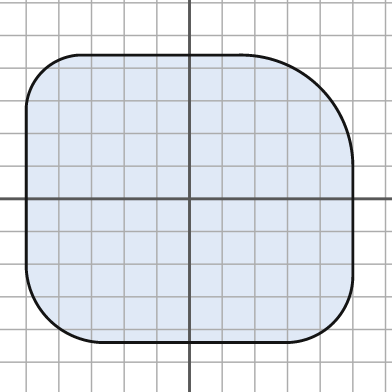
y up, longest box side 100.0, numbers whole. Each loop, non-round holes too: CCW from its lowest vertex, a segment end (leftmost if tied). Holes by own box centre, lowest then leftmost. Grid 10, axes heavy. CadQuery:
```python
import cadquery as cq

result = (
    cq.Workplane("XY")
    .moveTo(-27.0, -44.0)
    .lineTo(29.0, -44.0)
    .threePointArc((44.0, -38.0), (50.0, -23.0))
    .lineTo(50.0, 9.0)
    .threePointArc((40.0, 34.0), (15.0, 44.0))
    .lineTo(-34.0, 44.0)
    .threePointArc((-45.0, 39.0), (-50.0, 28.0))
    .lineTo(-50.0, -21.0)
    .threePointArc((-43.0, -37.0), (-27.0, -44.0))
    .close()
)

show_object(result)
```